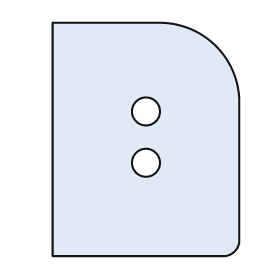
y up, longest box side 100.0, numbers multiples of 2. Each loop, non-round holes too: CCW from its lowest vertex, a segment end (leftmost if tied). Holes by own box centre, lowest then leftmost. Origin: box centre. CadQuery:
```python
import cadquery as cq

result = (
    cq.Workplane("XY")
    .moveTo(-40.0, -50.0)
    .lineTo(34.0, -50.0)
    .threePointArc((38.0, -48.0), (40.0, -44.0))
    .lineTo(40.0, 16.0)
    .threePointArc((30.0, 40.0), (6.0, 50.0))
    .lineTo(-40.0, 50.0)
    .close()
    .moveTo(0.0, -10.0)
    .circle(6.0)
    .moveTo(0.0, 12.0)
    .circle(6.0)
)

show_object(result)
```